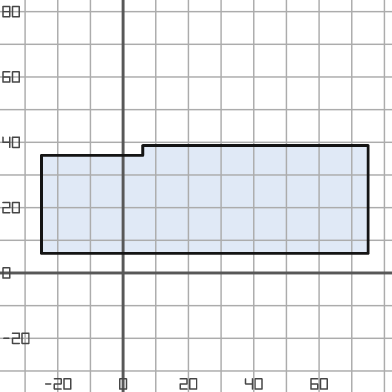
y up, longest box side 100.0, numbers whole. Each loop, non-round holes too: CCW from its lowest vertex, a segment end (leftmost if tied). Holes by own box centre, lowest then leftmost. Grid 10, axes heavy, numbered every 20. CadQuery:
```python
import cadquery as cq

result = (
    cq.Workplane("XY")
    .moveTo(-25.0, 6.0)
    .lineTo(75.0, 6.0)
    .lineTo(75.0, 39.0)
    .lineTo(6.0, 39.0)
    .lineTo(6.0, 36.0)
    .lineTo(-25.0, 36.0)
    .close()
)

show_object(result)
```